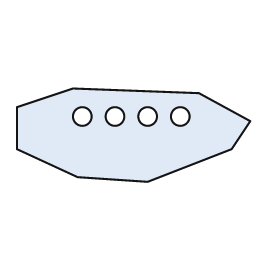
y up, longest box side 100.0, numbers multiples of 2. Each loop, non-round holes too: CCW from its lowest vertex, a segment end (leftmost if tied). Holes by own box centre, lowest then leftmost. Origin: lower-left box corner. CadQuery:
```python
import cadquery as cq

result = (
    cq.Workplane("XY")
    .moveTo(56.0, 0.0)
    .lineTo(92.0, 14.0)
    .lineTo(100.0, 26.0)
    .lineTo(78.0, 38.0)
    .lineTo(24.0, 40.0)
    .lineTo(0.0, 32.0)
    .lineTo(0.0, 14.0)
    .lineTo(26.0, 2.0)
    .close()
    .moveTo(28.0, 28.0)
    .circle(4.0)
    .moveTo(42.0, 28.0)
    .circle(4.0)
    .moveTo(56.0, 28.0)
    .circle(4.0)
    .moveTo(70.0, 28.0)
    .circle(4.0)
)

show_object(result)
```